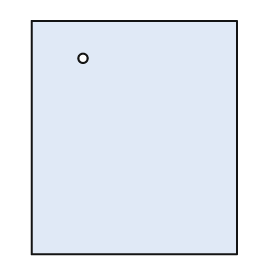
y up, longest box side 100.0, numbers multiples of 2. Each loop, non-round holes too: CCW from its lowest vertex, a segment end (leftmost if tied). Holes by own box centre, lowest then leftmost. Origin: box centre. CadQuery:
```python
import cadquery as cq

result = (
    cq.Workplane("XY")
    .moveTo(-44.0, -50.0)
    .lineTo(44.0, -50.0)
    .lineTo(44.0, 50.0)
    .lineTo(-44.0, 50.0)
    .close()
    .moveTo(-22.0, 34.0)
    .circle(2.0)
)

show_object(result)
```